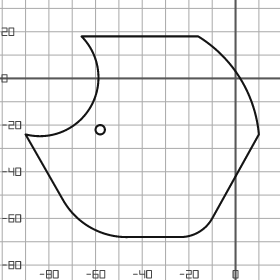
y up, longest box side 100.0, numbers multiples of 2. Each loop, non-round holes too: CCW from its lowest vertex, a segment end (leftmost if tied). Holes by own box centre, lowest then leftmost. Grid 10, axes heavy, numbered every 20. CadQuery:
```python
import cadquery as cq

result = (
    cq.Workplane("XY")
    .moveTo(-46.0, -68.0)
    .lineTo(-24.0, -68.0)
    .threePointArc((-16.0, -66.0), (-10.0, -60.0))
    .lineTo(10.0, -24.0)
    .threePointArc((2.0, 0.0), (-16.0, 18.0))
    .lineTo(-66.0, 18.0)
    .threePointArc((-62.0, -12.0), (-90.0, -24.0))
    .lineTo(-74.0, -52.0)
    .threePointArc((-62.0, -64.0), (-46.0, -68.0))
    .close()
    .moveTo(-58.0, -22.0)
    .circle(2.0)
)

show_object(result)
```